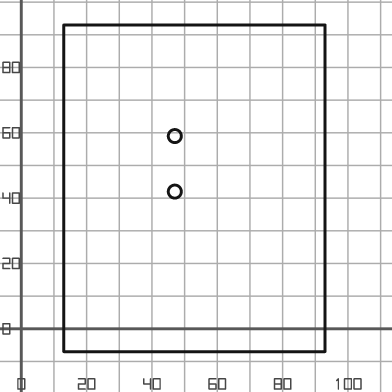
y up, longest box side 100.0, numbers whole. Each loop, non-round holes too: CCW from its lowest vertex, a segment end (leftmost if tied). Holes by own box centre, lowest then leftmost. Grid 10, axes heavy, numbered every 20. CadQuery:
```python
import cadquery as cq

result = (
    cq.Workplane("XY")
    .moveTo(13.0, -7.0)
    .lineTo(93.0, -7.0)
    .lineTo(93.0, 93.0)
    .lineTo(13.0, 93.0)
    .close()
    .moveTo(47.0, 42.0)
    .circle(2.0)
    .moveTo(47.0, 59.0)
    .circle(2.0)
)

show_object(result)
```